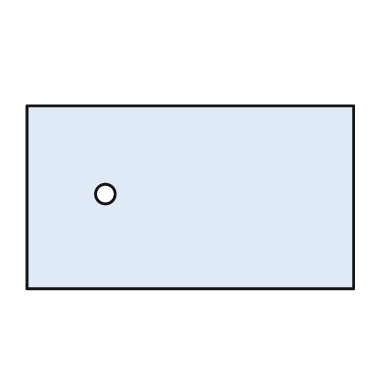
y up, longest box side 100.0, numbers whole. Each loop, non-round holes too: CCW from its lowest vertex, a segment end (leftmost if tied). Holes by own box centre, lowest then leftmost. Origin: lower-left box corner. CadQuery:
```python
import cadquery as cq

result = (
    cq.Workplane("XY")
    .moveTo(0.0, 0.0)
    .lineTo(100.0, 0.0)
    .lineTo(100.0, 56.0)
    .lineTo(0.0, 56.0)
    .close()
    .moveTo(24.0, 29.0)
    .circle(3.0)
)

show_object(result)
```